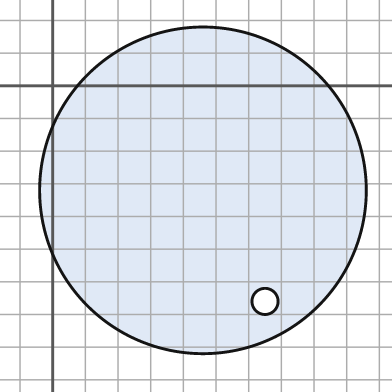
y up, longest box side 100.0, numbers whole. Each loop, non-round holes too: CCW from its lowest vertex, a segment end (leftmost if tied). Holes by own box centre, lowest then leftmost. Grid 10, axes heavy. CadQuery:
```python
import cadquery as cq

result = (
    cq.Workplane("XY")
    .moveTo(46.0, -32.0)
    .circle(50.0)
    .moveTo(65.0, -66.0)
    .circle(4.0)
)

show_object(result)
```